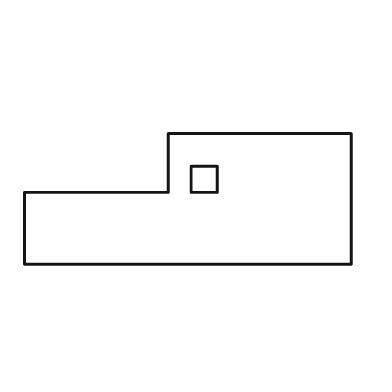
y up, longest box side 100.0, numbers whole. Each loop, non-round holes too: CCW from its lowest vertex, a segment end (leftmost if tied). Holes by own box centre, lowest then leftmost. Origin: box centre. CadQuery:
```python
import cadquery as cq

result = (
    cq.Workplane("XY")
    .moveTo(-50.0, -20.0)
    .lineTo(50.0, -20.0)
    .lineTo(50.0, 20.0)
    .lineTo(-6.0, 20.0)
    .lineTo(-6.0, 2.0)
    .lineTo(-50.0, 2.0)
    .close()
    .moveTo(1.0, 2.0)
    .lineTo(9.0, 2.0)
    .lineTo(9.0, 10.0)
    .lineTo(1.0, 10.0)
    .close()
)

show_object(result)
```